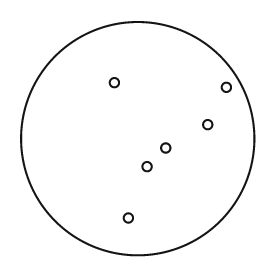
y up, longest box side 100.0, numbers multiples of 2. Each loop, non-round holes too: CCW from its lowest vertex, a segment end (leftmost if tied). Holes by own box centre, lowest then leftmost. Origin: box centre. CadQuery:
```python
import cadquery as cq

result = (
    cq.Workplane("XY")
    .moveTo(0.0, 0.0)
    .circle(50.0)
    .moveTo(-4.0, -34.0)
    .circle(2.0)
    .moveTo(4.0, -12.0)
    .circle(2.0)
    .moveTo(12.0, -4.0)
    .circle(2.0)
    .moveTo(30.0, 6.0)
    .circle(2.0)
    .moveTo(38.0, 22.0)
    .circle(2.0)
    .moveTo(-10.0, 24.0)
    .circle(2.0)
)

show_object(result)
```